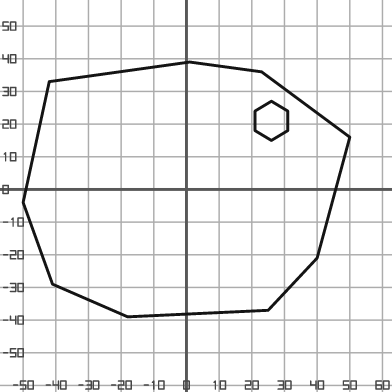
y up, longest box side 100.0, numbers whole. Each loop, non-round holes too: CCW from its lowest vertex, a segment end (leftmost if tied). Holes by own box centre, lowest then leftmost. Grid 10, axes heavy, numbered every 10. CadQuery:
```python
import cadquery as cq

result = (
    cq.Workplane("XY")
    .moveTo(-18.0, -39.0)
    .lineTo(25.0, -37.0)
    .lineTo(40.0, -21.0)
    .lineTo(50.0, 16.0)
    .lineTo(23.0, 36.0)
    .lineTo(1.0, 39.0)
    .lineTo(-42.0, 33.0)
    .lineTo(-50.0, -4.0)
    .lineTo(-41.0, -29.0)
    .close()
    .moveTo(26.0, 15.0)
    .lineTo(31.0, 18.0)
    .lineTo(31.0, 24.0)
    .lineTo(26.0, 27.0)
    .lineTo(21.0, 24.0)
    .lineTo(21.0, 18.0)
    .close()
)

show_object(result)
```